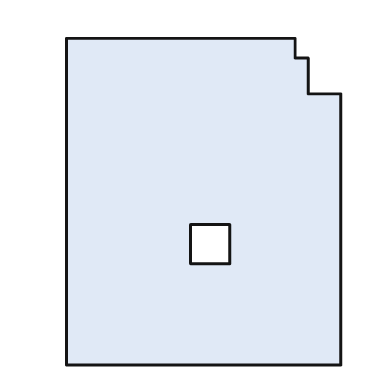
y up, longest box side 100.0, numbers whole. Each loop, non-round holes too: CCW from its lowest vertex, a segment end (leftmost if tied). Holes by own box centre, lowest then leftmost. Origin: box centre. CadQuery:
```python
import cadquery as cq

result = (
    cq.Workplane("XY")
    .moveTo(-42.0, -50.0)
    .lineTo(42.0, -50.0)
    .lineTo(42.0, 33.0)
    .lineTo(32.0, 33.0)
    .lineTo(32.0, 44.0)
    .lineTo(28.0, 44.0)
    .lineTo(28.0, 50.0)
    .lineTo(-42.0, 50.0)
    .close()
    .moveTo(-4.0, -19.0)
    .lineTo(8.0, -19.0)
    .lineTo(8.0, -7.0)
    .lineTo(-4.0, -7.0)
    .close()
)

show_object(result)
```